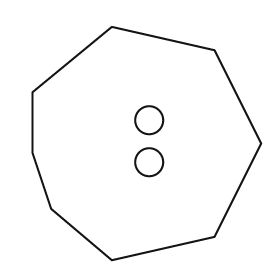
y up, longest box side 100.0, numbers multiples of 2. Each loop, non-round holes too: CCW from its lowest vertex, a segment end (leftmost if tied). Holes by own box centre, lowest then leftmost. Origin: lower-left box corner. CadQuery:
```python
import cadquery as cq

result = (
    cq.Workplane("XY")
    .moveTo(34.0, 0.0)
    .lineTo(78.0, 10.0)
    .lineTo(98.0, 50.0)
    .lineTo(78.0, 90.0)
    .lineTo(34.0, 100.0)
    .lineTo(0.0, 72.0)
    .lineTo(0.0, 46.0)
    .lineTo(8.0, 22.0)
    .close()
    .moveTo(50.0, 42.0)
    .circle(6.0)
    .moveTo(50.0, 60.0)
    .circle(6.0)
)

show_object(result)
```